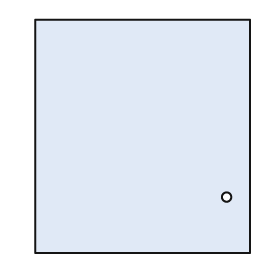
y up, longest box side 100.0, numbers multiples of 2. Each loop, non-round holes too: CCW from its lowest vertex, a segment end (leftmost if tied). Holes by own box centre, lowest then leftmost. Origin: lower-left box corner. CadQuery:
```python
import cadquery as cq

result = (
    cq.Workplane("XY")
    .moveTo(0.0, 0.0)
    .lineTo(92.0, 0.0)
    .lineTo(92.0, 100.0)
    .lineTo(0.0, 100.0)
    .close()
    .moveTo(82.0, 24.0)
    .circle(2.0)
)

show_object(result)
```